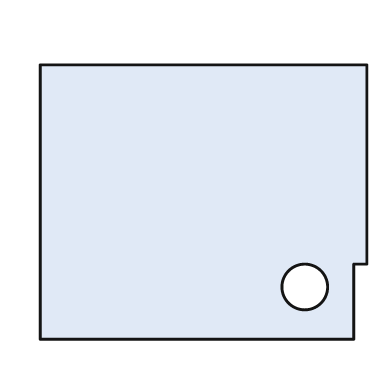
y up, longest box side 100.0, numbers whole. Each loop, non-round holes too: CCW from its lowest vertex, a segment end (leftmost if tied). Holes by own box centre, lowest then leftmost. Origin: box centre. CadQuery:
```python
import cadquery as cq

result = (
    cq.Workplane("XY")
    .moveTo(-50.0, -42.0)
    .lineTo(46.0, -42.0)
    .lineTo(46.0, -19.0)
    .lineTo(50.0, -19.0)
    .lineTo(50.0, 42.0)
    .lineTo(-50.0, 42.0)
    .close()
    .moveTo(31.0, -26.0)
    .circle(7.0)
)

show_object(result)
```